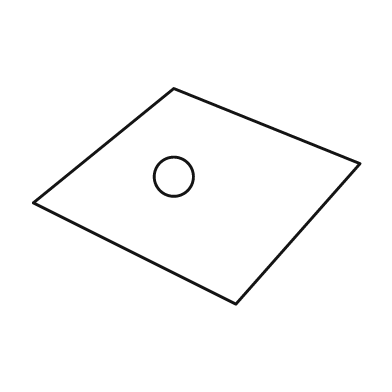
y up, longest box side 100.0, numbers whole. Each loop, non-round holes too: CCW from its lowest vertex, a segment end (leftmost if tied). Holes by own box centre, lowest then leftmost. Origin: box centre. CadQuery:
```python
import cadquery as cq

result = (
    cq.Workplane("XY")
    .moveTo(12.0, -33.0)
    .lineTo(50.0, 10.0)
    .lineTo(-7.0, 33.0)
    .lineTo(-50.0, -2.0)
    .close()
    .moveTo(-7.0, 6.0)
    .circle(6.0)
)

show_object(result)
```